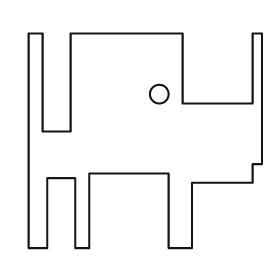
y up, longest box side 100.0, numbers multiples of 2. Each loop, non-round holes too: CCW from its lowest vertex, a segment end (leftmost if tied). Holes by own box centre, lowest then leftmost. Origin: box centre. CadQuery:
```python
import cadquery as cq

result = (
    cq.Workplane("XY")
    .moveTo(-50.0, -46.0)
    .lineTo(-42.0, -46.0)
    .lineTo(-42.0, -16.0)
    .lineTo(-30.0, -16.0)
    .lineTo(-30.0, -46.0)
    .lineTo(-24.0, -46.0)
    .lineTo(-24.0, -14.0)
    .lineTo(10.0, -14.0)
    .lineTo(10.0, -46.0)
    .lineTo(20.0, -46.0)
    .lineTo(20.0, -18.0)
    .lineTo(46.0, -18.0)
    .lineTo(46.0, -10.0)
    .lineTo(50.0, -10.0)
    .lineTo(50.0, 46.0)
    .lineTo(46.0, 46.0)
    .lineTo(46.0, 16.0)
    .lineTo(16.0, 16.0)
    .lineTo(16.0, 46.0)
    .lineTo(-32.0, 46.0)
    .lineTo(-32.0, 4.0)
    .lineTo(-44.0, 4.0)
    .lineTo(-44.0, 46.0)
    .lineTo(-50.0, 46.0)
    .close()
    .moveTo(6.0, 20.0)
    .circle(4.0)
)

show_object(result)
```